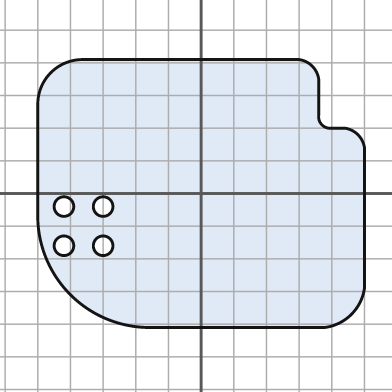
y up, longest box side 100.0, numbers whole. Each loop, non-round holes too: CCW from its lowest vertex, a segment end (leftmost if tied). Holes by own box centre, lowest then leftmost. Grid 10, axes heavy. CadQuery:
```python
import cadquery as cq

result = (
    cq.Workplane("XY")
    .moveTo(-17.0, -41.0)
    .lineTo(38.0, -41.0)
    .threePointArc((46.0, -37.0), (50.0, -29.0))
    .lineTo(50.0, 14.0)
    .threePointArc((48.0, 18.0), (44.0, 20.0))
    .lineTo(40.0, 20.0)
    .threePointArc((37.0, 21.0), (36.0, 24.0))
    .lineTo(36.0, 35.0)
    .threePointArc((34.0, 39.0), (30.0, 41.0))
    .lineTo(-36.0, 41.0)
    .threePointArc((-46.0, 37.0), (-50.0, 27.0))
    .lineTo(-50.0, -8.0)
    .threePointArc((-40.0, -31.0), (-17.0, -41.0))
    .close()
    .moveTo(-42.0, -16.0)
    .circle(3.0)
    .moveTo(-30.0, -16.0)
    .circle(3.0)
    .moveTo(-42.0, -4.0)
    .circle(3.0)
    .moveTo(-30.0, -4.0)
    .circle(3.0)
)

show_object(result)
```